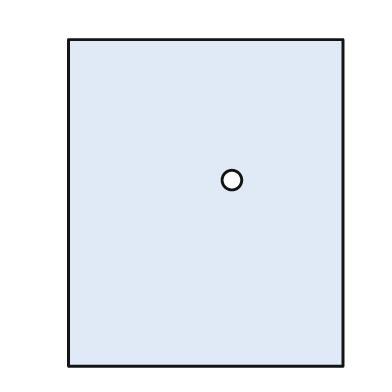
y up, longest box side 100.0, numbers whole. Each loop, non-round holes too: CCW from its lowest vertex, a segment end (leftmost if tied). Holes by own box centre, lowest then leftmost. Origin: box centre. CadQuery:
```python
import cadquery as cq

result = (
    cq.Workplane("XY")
    .moveTo(-42.0, -50.0)
    .lineTo(42.0, -50.0)
    .lineTo(42.0, 50.0)
    .lineTo(-42.0, 50.0)
    .close()
    .moveTo(8.0, 7.0)
    .circle(3.0)
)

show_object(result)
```